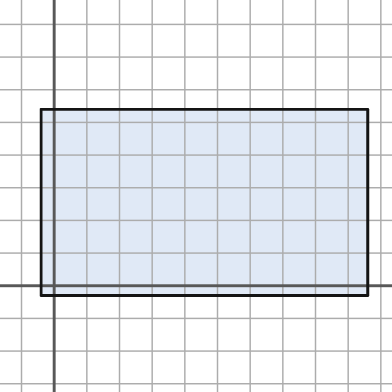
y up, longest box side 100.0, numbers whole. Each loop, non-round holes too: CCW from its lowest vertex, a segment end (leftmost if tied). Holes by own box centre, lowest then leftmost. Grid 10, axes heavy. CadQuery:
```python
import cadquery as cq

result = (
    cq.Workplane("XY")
    .moveTo(-4.0, -3.0)
    .lineTo(96.0, -3.0)
    .lineTo(96.0, 54.0)
    .lineTo(-4.0, 54.0)
    .close()
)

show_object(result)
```